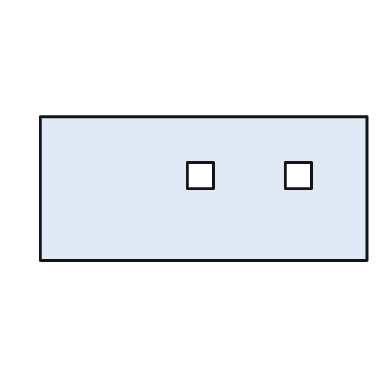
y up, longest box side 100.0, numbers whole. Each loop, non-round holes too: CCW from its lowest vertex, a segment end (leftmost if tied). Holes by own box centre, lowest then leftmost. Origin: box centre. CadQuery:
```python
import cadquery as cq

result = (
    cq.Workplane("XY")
    .moveTo(-50.0, -22.0)
    .lineTo(50.0, -22.0)
    .lineTo(50.0, 22.0)
    .lineTo(-50.0, 22.0)
    .close()
    .moveTo(-5.0, 0.0)
    .lineTo(3.0, 0.0)
    .lineTo(3.0, 8.0)
    .lineTo(-5.0, 8.0)
    .close()
    .moveTo(25.0, 0.0)
    .lineTo(33.0, 0.0)
    .lineTo(33.0, 8.0)
    .lineTo(25.0, 8.0)
    .close()
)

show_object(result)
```